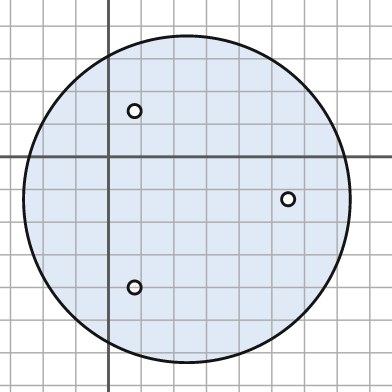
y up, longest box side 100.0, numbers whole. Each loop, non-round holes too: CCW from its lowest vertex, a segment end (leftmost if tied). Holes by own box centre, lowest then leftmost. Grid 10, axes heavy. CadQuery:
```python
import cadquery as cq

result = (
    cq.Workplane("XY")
    .moveTo(24.0, -13.0)
    .circle(50.0)
    .moveTo(8.0, -40.0)
    .circle(2.0)
    .moveTo(55.0, -13.0)
    .circle(2.0)
    .moveTo(8.0, 14.0)
    .circle(2.0)
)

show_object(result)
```